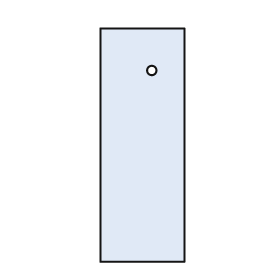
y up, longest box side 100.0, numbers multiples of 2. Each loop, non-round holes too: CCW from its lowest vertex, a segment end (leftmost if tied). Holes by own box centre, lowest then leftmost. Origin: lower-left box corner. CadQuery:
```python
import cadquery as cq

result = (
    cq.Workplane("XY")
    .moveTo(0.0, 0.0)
    .lineTo(36.0, 0.0)
    .lineTo(36.0, 100.0)
    .lineTo(0.0, 100.0)
    .close()
    .moveTo(22.0, 82.0)
    .circle(2.0)
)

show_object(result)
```